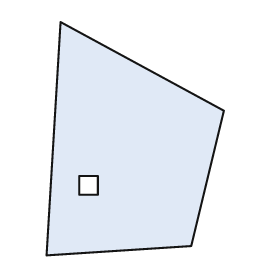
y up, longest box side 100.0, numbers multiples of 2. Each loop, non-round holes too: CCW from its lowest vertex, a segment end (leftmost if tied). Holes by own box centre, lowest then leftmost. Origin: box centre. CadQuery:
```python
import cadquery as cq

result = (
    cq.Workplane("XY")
    .moveTo(-38.0, -50.0)
    .lineTo(24.0, -46.0)
    .lineTo(38.0, 12.0)
    .lineTo(-32.0, 50.0)
    .close()
    .moveTo(-24.0, -24.0)
    .lineTo(-16.0, -24.0)
    .lineTo(-16.0, -16.0)
    .lineTo(-24.0, -16.0)
    .close()
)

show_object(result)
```